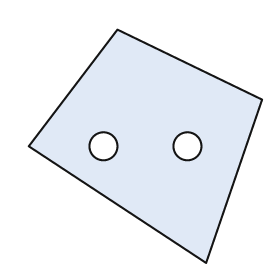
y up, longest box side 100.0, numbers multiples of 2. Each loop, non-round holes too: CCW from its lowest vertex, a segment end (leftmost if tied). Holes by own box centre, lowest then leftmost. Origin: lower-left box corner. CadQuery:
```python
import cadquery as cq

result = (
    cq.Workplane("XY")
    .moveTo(76.0, 0.0)
    .lineTo(100.0, 70.0)
    .lineTo(38.0, 100.0)
    .lineTo(0.0, 50.0)
    .close()
    .moveTo(32.0, 50.0)
    .circle(6.0)
    .moveTo(68.0, 50.0)
    .circle(6.0)
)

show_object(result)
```